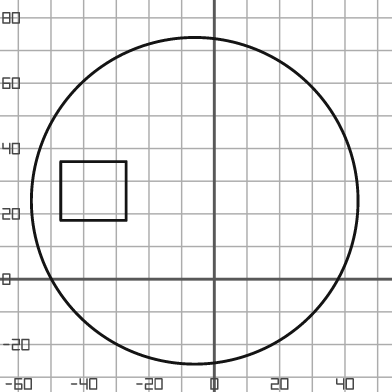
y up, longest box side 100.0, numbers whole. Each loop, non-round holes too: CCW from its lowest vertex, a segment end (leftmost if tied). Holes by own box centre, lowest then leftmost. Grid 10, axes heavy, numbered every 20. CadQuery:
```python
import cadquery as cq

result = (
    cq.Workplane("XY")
    .moveTo(-6.0, 24.0)
    .circle(50.0)
    .moveTo(-47.0, 18.0)
    .lineTo(-27.0, 18.0)
    .lineTo(-27.0, 36.0)
    .lineTo(-47.0, 36.0)
    .close()
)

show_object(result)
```